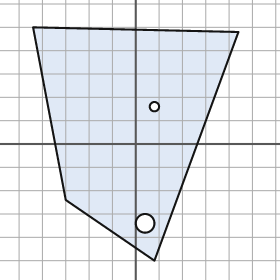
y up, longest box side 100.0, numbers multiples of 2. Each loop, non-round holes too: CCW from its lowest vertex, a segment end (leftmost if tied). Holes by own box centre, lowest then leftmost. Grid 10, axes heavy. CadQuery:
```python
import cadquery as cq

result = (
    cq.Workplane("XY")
    .moveTo(8.0, -50.0)
    .lineTo(44.0, 48.0)
    .lineTo(-44.0, 50.0)
    .lineTo(-30.0, -24.0)
    .close()
    .moveTo(4.0, -34.0)
    .circle(4.0)
    .moveTo(8.0, 16.0)
    .circle(2.0)
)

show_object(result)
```